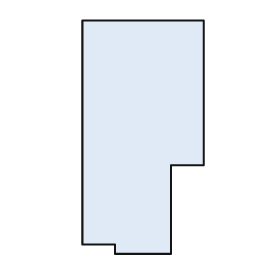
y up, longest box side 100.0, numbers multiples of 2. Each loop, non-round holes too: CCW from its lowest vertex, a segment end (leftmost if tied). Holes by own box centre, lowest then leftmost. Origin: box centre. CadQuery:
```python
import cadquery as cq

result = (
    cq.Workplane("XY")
    .moveTo(-12.0, -50.0)
    .lineTo(12.0, -50.0)
    .lineTo(12.0, -12.0)
    .lineTo(26.0, -12.0)
    .lineTo(26.0, 50.0)
    .lineTo(-26.0, 50.0)
    .lineTo(-26.0, -46.0)
    .lineTo(-12.0, -46.0)
    .close()
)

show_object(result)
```